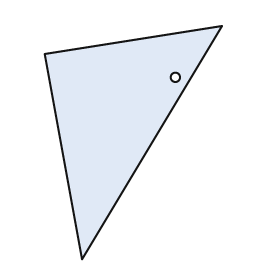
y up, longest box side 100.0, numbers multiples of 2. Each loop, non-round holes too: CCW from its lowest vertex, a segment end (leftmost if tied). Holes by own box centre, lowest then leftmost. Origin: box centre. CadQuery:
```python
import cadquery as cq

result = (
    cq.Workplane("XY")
    .moveTo(-22.0, -50.0)
    .lineTo(38.0, 50.0)
    .lineTo(-38.0, 38.0)
    .close()
    .moveTo(18.0, 28.0)
    .circle(2.0)
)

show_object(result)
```